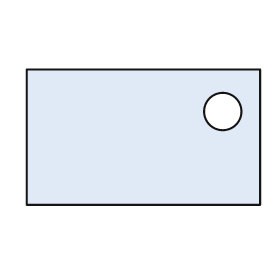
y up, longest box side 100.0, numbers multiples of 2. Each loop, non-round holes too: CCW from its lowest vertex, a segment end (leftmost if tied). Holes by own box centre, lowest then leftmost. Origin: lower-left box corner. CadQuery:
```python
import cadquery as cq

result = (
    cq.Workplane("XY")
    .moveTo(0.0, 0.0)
    .lineTo(100.0, 0.0)
    .lineTo(100.0, 58.0)
    .lineTo(0.0, 58.0)
    .close()
    .moveTo(84.0, 40.0)
    .circle(8.0)
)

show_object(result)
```